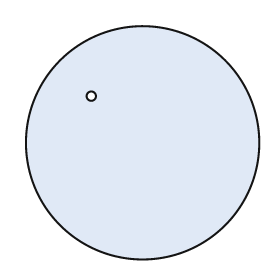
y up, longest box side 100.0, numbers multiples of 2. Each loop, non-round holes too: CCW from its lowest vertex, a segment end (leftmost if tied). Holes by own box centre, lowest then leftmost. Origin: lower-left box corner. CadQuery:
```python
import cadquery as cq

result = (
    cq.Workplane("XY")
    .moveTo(50.0, 50.0)
    .circle(50.0)
    .moveTo(28.0, 70.0)
    .circle(2.0)
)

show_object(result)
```